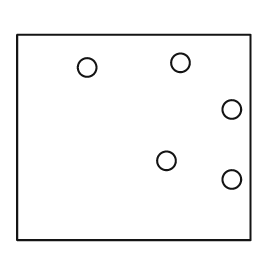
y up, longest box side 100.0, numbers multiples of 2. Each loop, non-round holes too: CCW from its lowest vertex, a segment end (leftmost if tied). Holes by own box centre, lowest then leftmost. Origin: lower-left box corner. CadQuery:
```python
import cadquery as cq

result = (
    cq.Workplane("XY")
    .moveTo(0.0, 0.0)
    .lineTo(100.0, 0.0)
    .lineTo(100.0, 88.0)
    .lineTo(0.0, 88.0)
    .close()
    .moveTo(92.0, 26.0)
    .circle(4.0)
    .moveTo(64.0, 34.0)
    .circle(4.0)
    .moveTo(92.0, 56.0)
    .circle(4.0)
    .moveTo(30.0, 74.0)
    .circle(4.0)
    .moveTo(70.0, 76.0)
    .circle(4.0)
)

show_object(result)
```